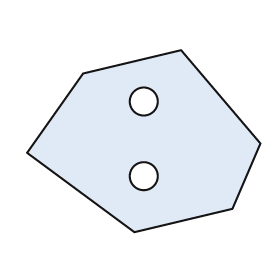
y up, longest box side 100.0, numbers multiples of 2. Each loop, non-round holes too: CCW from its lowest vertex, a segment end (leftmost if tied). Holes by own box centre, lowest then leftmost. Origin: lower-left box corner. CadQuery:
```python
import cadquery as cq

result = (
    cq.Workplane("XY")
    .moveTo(46.0, 0.0)
    .lineTo(88.0, 10.0)
    .lineTo(100.0, 38.0)
    .lineTo(66.0, 78.0)
    .lineTo(24.0, 68.0)
    .lineTo(0.0, 34.0)
    .close()
    .moveTo(50.0, 24.0)
    .circle(6.0)
    .moveTo(50.0, 56.0)
    .circle(6.0)
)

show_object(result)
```